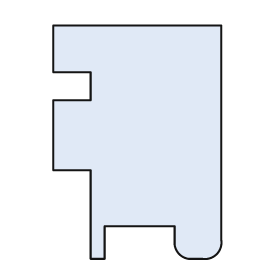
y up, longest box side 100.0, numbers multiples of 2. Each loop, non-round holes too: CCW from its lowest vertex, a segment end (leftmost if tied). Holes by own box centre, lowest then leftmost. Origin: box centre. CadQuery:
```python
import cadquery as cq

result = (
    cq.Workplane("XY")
    .moveTo(-20.0, -50.0)
    .lineTo(-14.0, -50.0)
    .lineTo(-14.0, -36.0)
    .lineTo(16.0, -36.0)
    .lineTo(16.0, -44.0)
    .threePointArc((18.0, -48.0), (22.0, -50.0))
    .lineTo(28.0, -50.0)
    .threePointArc((34.0, -48.0), (36.0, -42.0))
    .lineTo(36.0, 50.0)
    .lineTo(-36.0, 50.0)
    .lineTo(-36.0, 30.0)
    .lineTo(-20.0, 30.0)
    .lineTo(-20.0, 18.0)
    .lineTo(-36.0, 18.0)
    .lineTo(-36.0, -12.0)
    .lineTo(-20.0, -12.0)
    .close()
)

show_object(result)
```